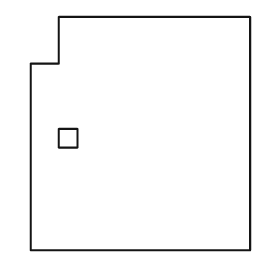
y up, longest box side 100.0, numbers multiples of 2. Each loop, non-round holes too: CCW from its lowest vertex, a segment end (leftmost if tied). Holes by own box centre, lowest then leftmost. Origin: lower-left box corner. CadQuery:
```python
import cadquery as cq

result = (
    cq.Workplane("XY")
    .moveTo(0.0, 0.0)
    .lineTo(94.0, 0.0)
    .lineTo(94.0, 100.0)
    .lineTo(12.0, 100.0)
    .lineTo(12.0, 80.0)
    .lineTo(0.0, 80.0)
    .close()
    .moveTo(12.0, 44.0)
    .lineTo(20.0, 44.0)
    .lineTo(20.0, 52.0)
    .lineTo(12.0, 52.0)
    .close()
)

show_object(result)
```